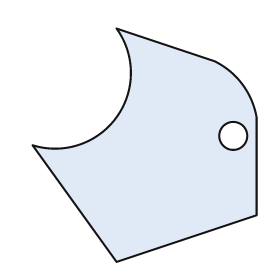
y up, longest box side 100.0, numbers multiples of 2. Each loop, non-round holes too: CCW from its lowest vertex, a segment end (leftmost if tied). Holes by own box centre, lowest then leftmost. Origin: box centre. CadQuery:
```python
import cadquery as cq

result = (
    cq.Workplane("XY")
    .moveTo(-12.0, -50.0)
    .lineTo(48.0, -30.0)
    .lineTo(48.0, 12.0)
    .threePointArc((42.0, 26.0), (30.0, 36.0))
    .lineTo(-12.0, 50.0)
    .threePointArc((-12.0, 12.0), (-48.0, 0.0))
    .close()
    .moveTo(38.0, 4.0)
    .circle(6.0)
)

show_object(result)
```